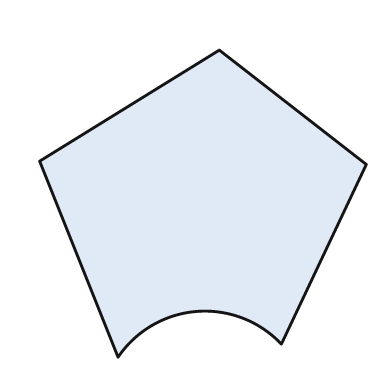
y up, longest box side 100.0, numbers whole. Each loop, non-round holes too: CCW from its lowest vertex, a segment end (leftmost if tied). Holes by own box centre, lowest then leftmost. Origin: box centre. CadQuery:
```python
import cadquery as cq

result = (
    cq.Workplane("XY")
    .moveTo(-26.0, -47.0)
    .threePointArc((-2.0, -33.0), (24.0, -43.0))
    .lineTo(50.0, 12.0)
    .lineTo(5.0, 47.0)
    .lineTo(-50.0, 13.0)
    .close()
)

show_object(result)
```